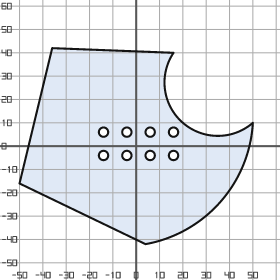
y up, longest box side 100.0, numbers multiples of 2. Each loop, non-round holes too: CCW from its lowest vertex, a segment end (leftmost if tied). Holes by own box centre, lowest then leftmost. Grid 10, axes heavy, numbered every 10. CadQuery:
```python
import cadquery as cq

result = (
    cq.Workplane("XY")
    .moveTo(4.0, -42.0)
    .threePointArc((36.0, -24.0), (50.0, 10.0))
    .threePointArc((20.0, 10.0), (16.0, 40.0))
    .lineTo(-36.0, 42.0)
    .lineTo(-50.0, -16.0)
    .close()
    .moveTo(-14.0, -4.0)
    .circle(2.0)
    .moveTo(-4.0, -4.0)
    .circle(2.0)
    .moveTo(6.0, -4.0)
    .circle(2.0)
    .moveTo(16.0, -4.0)
    .circle(2.0)
    .moveTo(-14.0, 6.0)
    .circle(2.0)
    .moveTo(-4.0, 6.0)
    .circle(2.0)
    .moveTo(6.0, 6.0)
    .circle(2.0)
    .moveTo(16.0, 6.0)
    .circle(2.0)
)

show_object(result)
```